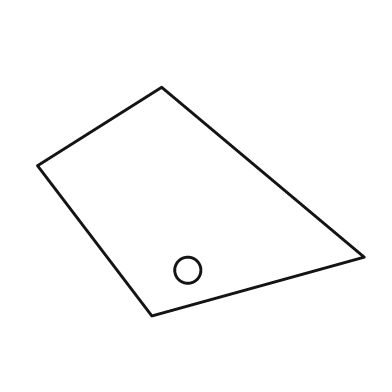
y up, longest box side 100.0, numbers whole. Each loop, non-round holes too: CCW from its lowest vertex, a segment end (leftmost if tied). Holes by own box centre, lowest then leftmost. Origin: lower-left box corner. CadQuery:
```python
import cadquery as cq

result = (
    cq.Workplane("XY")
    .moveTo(35.0, 0.0)
    .lineTo(100.0, 18.0)
    .lineTo(38.0, 70.0)
    .lineTo(0.0, 46.0)
    .close()
    .moveTo(46.0, 14.0)
    .circle(4.0)
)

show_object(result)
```